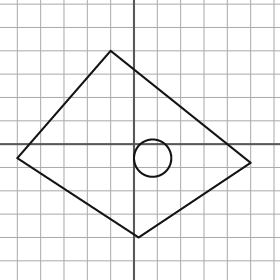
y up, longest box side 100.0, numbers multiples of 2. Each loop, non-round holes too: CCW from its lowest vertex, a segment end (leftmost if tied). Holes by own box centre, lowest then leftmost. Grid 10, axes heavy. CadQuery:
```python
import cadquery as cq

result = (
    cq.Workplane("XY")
    .moveTo(2.0, -40.0)
    .lineTo(50.0, -8.0)
    .lineTo(-10.0, 40.0)
    .lineTo(-50.0, -6.0)
    .close()
    .moveTo(8.0, -6.0)
    .circle(8.0)
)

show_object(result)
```